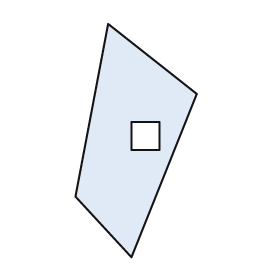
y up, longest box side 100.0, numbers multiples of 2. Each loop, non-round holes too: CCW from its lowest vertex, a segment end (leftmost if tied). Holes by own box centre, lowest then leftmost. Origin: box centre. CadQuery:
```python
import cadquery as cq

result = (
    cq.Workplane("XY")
    .moveTo(-2.0, -50.0)
    .lineTo(26.0, 20.0)
    .lineTo(-12.0, 50.0)
    .lineTo(-26.0, -24.0)
    .close()
    .moveTo(-2.0, -4.0)
    .lineTo(10.0, -4.0)
    .lineTo(10.0, 8.0)
    .lineTo(-2.0, 8.0)
    .close()
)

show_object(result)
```